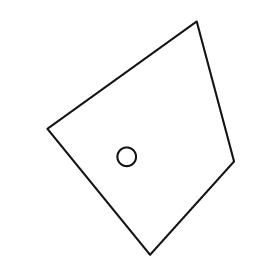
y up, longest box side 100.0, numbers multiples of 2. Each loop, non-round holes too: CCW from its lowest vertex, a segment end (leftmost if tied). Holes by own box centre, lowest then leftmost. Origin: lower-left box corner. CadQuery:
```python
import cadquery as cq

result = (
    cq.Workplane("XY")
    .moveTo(44.0, 0.0)
    .lineTo(80.0, 40.0)
    .lineTo(64.0, 100.0)
    .lineTo(0.0, 54.0)
    .close()
    .moveTo(34.0, 42.0)
    .circle(4.0)
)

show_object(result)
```